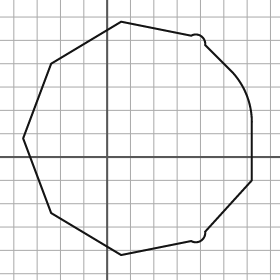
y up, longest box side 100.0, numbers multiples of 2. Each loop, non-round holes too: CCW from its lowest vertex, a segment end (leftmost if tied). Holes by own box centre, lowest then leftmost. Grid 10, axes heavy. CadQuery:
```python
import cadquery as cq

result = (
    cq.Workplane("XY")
    .moveTo(6.0, -42.0)
    .lineTo(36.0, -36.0)
    .threePointArc((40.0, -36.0), (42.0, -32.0))
    .lineTo(62.0, -10.0)
    .lineTo(62.0, 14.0)
    .threePointArc((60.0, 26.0), (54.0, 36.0))
    .lineTo(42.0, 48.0)
    .threePointArc((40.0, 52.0), (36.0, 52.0))
    .lineTo(6.0, 58.0)
    .lineTo(-24.0, 40.0)
    .lineTo(-36.0, 8.0)
    .lineTo(-24.0, -24.0)
    .close()
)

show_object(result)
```